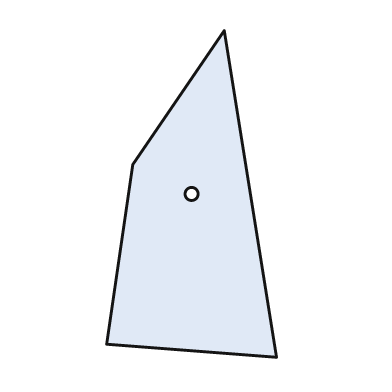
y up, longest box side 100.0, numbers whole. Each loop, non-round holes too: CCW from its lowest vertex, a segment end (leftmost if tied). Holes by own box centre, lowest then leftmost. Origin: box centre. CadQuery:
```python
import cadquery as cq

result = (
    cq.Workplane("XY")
    .moveTo(26.0, -50.0)
    .lineTo(10.0, 50.0)
    .lineTo(-18.0, 9.0)
    .lineTo(-26.0, -46.0)
    .close()
    .moveTo(0.0, 0.0)
    .circle(2.0)
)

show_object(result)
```